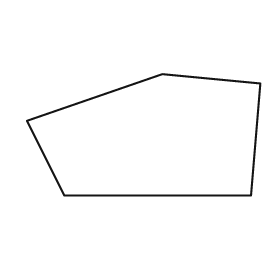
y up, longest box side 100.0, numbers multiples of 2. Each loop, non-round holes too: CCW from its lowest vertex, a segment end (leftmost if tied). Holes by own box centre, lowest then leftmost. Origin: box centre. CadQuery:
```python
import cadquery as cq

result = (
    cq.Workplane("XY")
    .moveTo(-34.0, -26.0)
    .lineTo(46.0, -26.0)
    .lineTo(50.0, 22.0)
    .lineTo(8.0, 26.0)
    .lineTo(-50.0, 6.0)
    .close()
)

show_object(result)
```